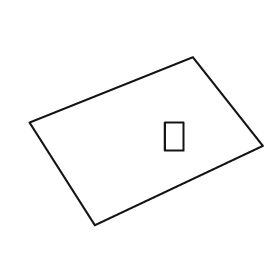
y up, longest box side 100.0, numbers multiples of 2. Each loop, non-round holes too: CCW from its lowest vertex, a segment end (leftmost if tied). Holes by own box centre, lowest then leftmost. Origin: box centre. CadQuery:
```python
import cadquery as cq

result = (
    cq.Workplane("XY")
    .moveTo(-22.0, -36.0)
    .lineTo(50.0, -2.0)
    .lineTo(20.0, 36.0)
    .lineTo(-50.0, 8.0)
    .close()
    .moveTo(8.0, -4.0)
    .lineTo(16.0, -4.0)
    .lineTo(16.0, 8.0)
    .lineTo(8.0, 8.0)
    .close()
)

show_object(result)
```